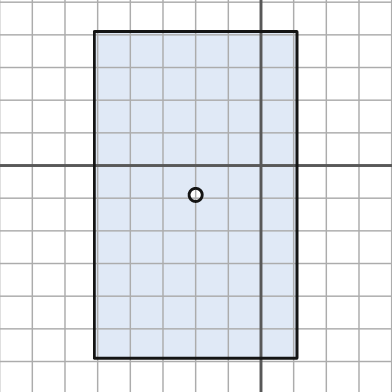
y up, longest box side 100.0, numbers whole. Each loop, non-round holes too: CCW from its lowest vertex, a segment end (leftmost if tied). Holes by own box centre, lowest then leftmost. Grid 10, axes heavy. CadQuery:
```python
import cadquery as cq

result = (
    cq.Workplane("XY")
    .moveTo(-51.0, -59.0)
    .lineTo(11.0, -59.0)
    .lineTo(11.0, 41.0)
    .lineTo(-51.0, 41.0)
    .close()
    .moveTo(-20.0, -9.0)
    .circle(2.0)
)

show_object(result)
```